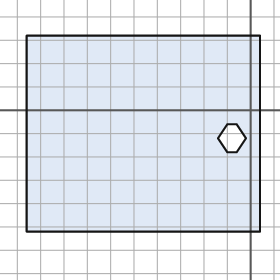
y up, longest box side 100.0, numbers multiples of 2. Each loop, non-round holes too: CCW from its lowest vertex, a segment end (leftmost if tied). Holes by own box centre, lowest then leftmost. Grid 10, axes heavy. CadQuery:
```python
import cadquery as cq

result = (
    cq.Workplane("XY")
    .moveTo(-96.0, -52.0)
    .lineTo(4.0, -52.0)
    .lineTo(4.0, 32.0)
    .lineTo(-96.0, 32.0)
    .close()
    .moveTo(-10.0, -18.0)
    .lineTo(-6.0, -18.0)
    .lineTo(-2.0, -12.0)
    .lineTo(-6.0, -6.0)
    .lineTo(-10.0, -6.0)
    .lineTo(-14.0, -12.0)
    .close()
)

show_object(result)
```